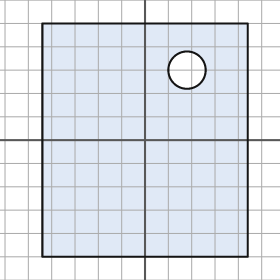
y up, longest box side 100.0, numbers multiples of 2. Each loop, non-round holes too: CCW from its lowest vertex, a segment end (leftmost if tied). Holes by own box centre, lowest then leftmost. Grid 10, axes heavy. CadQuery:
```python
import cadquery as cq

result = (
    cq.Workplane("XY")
    .moveTo(-44.0, -50.0)
    .lineTo(44.0, -50.0)
    .lineTo(44.0, 50.0)
    .lineTo(-44.0, 50.0)
    .close()
    .moveTo(18.0, 30.0)
    .circle(8.0)
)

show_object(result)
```